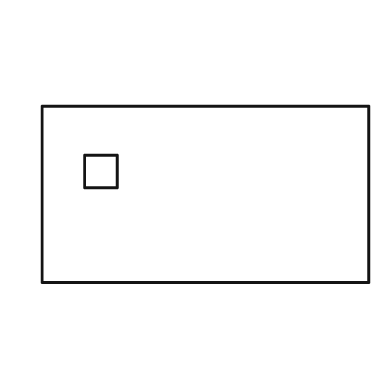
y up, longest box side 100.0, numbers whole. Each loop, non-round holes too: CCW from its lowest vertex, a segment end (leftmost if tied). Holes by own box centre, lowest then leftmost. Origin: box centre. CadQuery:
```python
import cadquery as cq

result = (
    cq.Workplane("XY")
    .moveTo(-50.0, -27.0)
    .lineTo(50.0, -27.0)
    .lineTo(50.0, 27.0)
    .lineTo(-50.0, 27.0)
    .close()
    .moveTo(-37.0, 2.0)
    .lineTo(-27.0, 2.0)
    .lineTo(-27.0, 12.0)
    .lineTo(-37.0, 12.0)
    .close()
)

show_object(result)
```